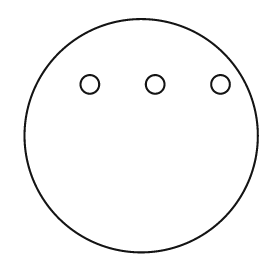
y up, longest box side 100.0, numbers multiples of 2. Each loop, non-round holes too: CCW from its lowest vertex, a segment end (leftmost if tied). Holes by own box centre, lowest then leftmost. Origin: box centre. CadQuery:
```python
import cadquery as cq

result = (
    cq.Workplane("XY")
    .moveTo(0.0, 0.0)
    .circle(50.0)
    .moveTo(-22.0, 22.0)
    .circle(4.0)
    .moveTo(6.0, 22.0)
    .circle(4.0)
    .moveTo(34.0, 22.0)
    .circle(4.0)
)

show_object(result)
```